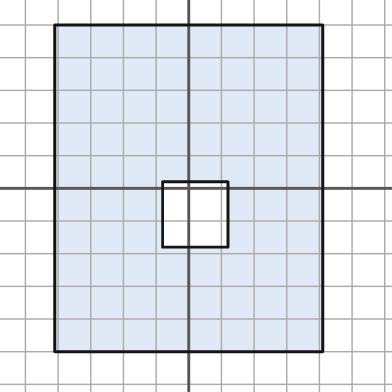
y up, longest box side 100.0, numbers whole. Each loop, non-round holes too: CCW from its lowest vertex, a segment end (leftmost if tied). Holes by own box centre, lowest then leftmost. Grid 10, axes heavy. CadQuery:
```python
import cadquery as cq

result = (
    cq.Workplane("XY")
    .moveTo(-41.0, -50.0)
    .lineTo(41.0, -50.0)
    .lineTo(41.0, 50.0)
    .lineTo(-41.0, 50.0)
    .close()
    .moveTo(-8.0, -18.0)
    .lineTo(12.0, -18.0)
    .lineTo(12.0, 2.0)
    .lineTo(-8.0, 2.0)
    .close()
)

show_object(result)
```